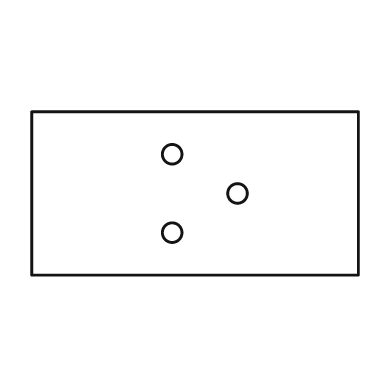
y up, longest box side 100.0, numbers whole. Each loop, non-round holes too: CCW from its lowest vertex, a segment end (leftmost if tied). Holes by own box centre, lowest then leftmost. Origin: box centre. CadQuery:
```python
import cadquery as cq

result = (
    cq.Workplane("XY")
    .moveTo(-50.0, -25.0)
    .lineTo(50.0, -25.0)
    .lineTo(50.0, 25.0)
    .lineTo(-50.0, 25.0)
    .close()
    .moveTo(-7.0, -12.0)
    .circle(3.0)
    .moveTo(13.0, 0.0)
    .circle(3.0)
    .moveTo(-7.0, 12.0)
    .circle(3.0)
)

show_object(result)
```